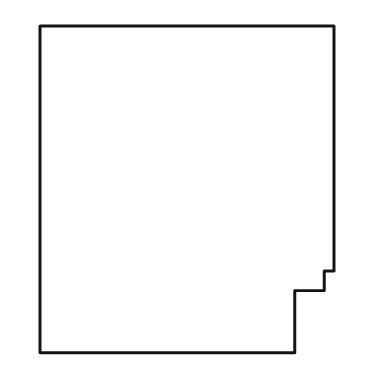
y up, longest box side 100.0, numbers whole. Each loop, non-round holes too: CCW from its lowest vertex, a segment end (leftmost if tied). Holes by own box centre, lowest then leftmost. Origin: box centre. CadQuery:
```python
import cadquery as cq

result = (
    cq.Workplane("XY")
    .moveTo(-45.0, -50.0)
    .lineTo(33.0, -50.0)
    .lineTo(33.0, -31.0)
    .lineTo(42.0, -31.0)
    .lineTo(42.0, -25.0)
    .lineTo(45.0, -25.0)
    .lineTo(45.0, 50.0)
    .lineTo(-45.0, 50.0)
    .close()
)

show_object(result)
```